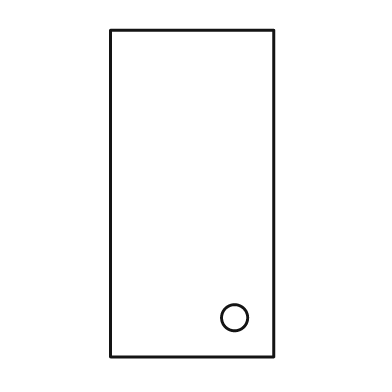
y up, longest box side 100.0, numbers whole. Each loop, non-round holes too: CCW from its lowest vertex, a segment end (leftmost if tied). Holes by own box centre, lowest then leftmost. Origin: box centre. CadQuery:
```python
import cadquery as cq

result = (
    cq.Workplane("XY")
    .moveTo(-25.0, -50.0)
    .lineTo(25.0, -50.0)
    .lineTo(25.0, 50.0)
    .lineTo(-25.0, 50.0)
    .close()
    .moveTo(13.0, -38.0)
    .circle(4.0)
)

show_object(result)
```